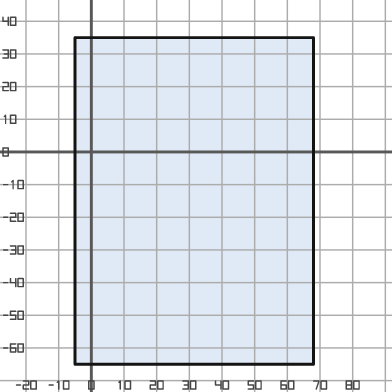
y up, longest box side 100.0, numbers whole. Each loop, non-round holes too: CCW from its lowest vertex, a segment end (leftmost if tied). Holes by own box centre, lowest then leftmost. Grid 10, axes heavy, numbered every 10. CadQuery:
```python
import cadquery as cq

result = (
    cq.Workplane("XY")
    .moveTo(-5.0, -65.0)
    .lineTo(68.0, -65.0)
    .lineTo(68.0, 35.0)
    .lineTo(-5.0, 35.0)
    .close()
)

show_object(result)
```